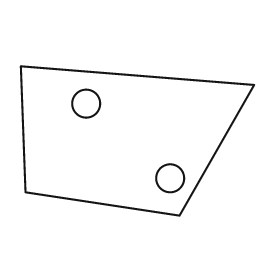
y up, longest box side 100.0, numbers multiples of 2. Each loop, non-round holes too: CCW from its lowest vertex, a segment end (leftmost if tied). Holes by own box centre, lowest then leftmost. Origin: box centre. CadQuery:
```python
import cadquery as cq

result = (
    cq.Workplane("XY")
    .moveTo(18.0, -32.0)
    .lineTo(50.0, 24.0)
    .lineTo(-50.0, 32.0)
    .lineTo(-48.0, -22.0)
    .close()
    .moveTo(14.0, -16.0)
    .circle(6.0)
    .moveTo(-22.0, 16.0)
    .circle(6.0)
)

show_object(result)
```